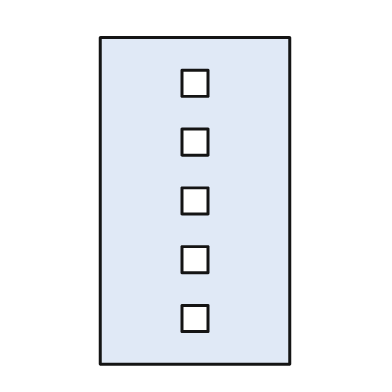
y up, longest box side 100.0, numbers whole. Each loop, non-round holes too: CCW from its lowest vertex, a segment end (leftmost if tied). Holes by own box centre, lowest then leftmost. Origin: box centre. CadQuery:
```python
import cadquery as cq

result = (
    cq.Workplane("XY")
    .moveTo(-29.0, -50.0)
    .lineTo(29.0, -50.0)
    .lineTo(29.0, 50.0)
    .lineTo(-29.0, 50.0)
    .close()
    .moveTo(-4.0, -40.0)
    .lineTo(4.0, -40.0)
    .lineTo(4.0, -32.0)
    .lineTo(-4.0, -32.0)
    .close()
    .moveTo(-4.0, -22.0)
    .lineTo(4.0, -22.0)
    .lineTo(4.0, -14.0)
    .lineTo(-4.0, -14.0)
    .close()
    .moveTo(-4.0, -4.0)
    .lineTo(4.0, -4.0)
    .lineTo(4.0, 4.0)
    .lineTo(-4.0, 4.0)
    .close()
    .moveTo(-4.0, 14.0)
    .lineTo(4.0, 14.0)
    .lineTo(4.0, 22.0)
    .lineTo(-4.0, 22.0)
    .close()
    .moveTo(-4.0, 32.0)
    .lineTo(4.0, 32.0)
    .lineTo(4.0, 40.0)
    .lineTo(-4.0, 40.0)
    .close()
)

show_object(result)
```